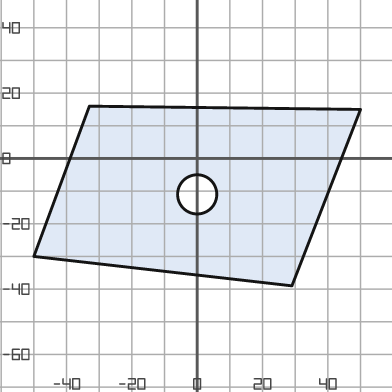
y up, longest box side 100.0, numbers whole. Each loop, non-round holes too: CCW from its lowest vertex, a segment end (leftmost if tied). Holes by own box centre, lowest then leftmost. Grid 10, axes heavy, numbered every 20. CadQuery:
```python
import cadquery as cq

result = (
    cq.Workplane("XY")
    .moveTo(29.0, -39.0)
    .lineTo(50.0, 15.0)
    .lineTo(-33.0, 16.0)
    .lineTo(-50.0, -30.0)
    .close()
    .moveTo(0.0, -11.0)
    .circle(6.0)
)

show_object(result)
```